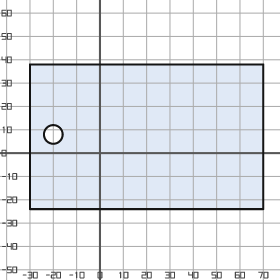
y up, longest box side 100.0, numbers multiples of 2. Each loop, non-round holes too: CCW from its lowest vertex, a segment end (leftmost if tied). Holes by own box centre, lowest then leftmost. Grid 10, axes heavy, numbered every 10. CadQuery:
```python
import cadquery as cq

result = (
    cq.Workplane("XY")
    .moveTo(-30.0, -24.0)
    .lineTo(70.0, -24.0)
    .lineTo(70.0, 38.0)
    .lineTo(-30.0, 38.0)
    .close()
    .moveTo(-20.0, 8.0)
    .circle(4.0)
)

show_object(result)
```